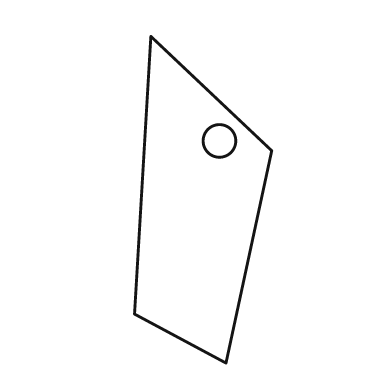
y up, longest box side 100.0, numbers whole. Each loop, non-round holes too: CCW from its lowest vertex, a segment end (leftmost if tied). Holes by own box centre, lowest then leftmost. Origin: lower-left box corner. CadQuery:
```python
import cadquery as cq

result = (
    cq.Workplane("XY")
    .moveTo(28.0, 0.0)
    .lineTo(42.0, 65.0)
    .lineTo(5.0, 100.0)
    .lineTo(0.0, 15.0)
    .close()
    .moveTo(26.0, 68.0)
    .circle(5.0)
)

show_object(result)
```